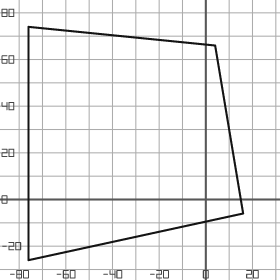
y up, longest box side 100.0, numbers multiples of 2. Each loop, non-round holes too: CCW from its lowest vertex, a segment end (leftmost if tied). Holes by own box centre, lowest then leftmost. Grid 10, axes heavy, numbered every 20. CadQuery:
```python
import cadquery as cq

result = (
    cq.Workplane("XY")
    .moveTo(-76.0, -26.0)
    .lineTo(16.0, -6.0)
    .lineTo(4.0, 66.0)
    .lineTo(-76.0, 74.0)
    .close()
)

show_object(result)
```